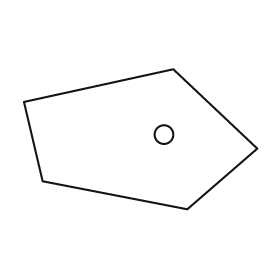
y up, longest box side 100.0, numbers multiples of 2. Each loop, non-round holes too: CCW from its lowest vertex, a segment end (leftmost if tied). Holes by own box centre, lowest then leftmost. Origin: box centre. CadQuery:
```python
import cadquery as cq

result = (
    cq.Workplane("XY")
    .moveTo(20.0, -30.0)
    .lineTo(50.0, -4.0)
    .lineTo(14.0, 30.0)
    .lineTo(-50.0, 16.0)
    .lineTo(-42.0, -18.0)
    .close()
    .moveTo(10.0, 2.0)
    .circle(4.0)
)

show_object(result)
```